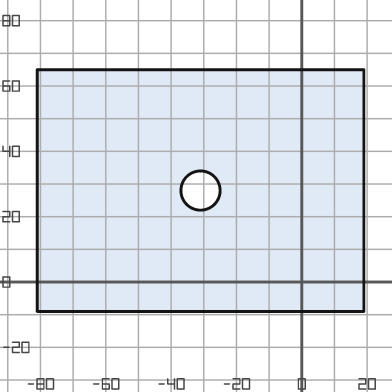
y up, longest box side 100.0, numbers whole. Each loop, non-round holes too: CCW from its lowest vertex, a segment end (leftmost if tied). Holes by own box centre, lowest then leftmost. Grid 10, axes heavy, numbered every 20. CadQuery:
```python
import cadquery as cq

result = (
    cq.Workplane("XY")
    .moveTo(-81.0, -9.0)
    .lineTo(19.0, -9.0)
    .lineTo(19.0, 65.0)
    .lineTo(-81.0, 65.0)
    .close()
    .moveTo(-31.0, 28.0)
    .circle(6.0)
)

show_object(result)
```